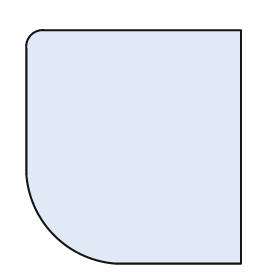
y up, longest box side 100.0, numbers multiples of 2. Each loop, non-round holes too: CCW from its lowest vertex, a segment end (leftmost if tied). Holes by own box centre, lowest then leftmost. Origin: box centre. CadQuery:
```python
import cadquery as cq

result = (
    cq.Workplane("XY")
    .moveTo(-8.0, -50.0)
    .lineTo(46.0, -50.0)
    .lineTo(46.0, 50.0)
    .lineTo(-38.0, 50.0)
    .threePointArc((-44.0, 48.0), (-46.0, 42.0))
    .lineTo(-46.0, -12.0)
    .threePointArc((-34.0, -38.0), (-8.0, -50.0))
    .close()
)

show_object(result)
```